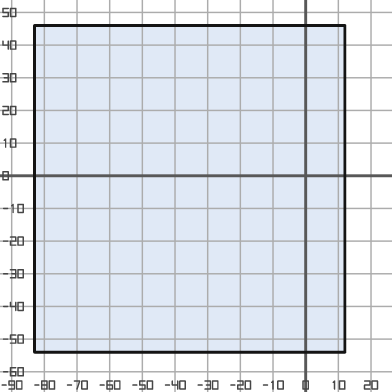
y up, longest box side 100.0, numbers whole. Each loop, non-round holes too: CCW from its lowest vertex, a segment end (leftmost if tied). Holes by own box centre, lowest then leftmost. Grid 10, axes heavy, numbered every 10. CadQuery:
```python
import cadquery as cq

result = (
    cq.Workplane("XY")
    .moveTo(-83.0, -54.0)
    .lineTo(12.0, -54.0)
    .lineTo(12.0, 46.0)
    .lineTo(-83.0, 46.0)
    .close()
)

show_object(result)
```